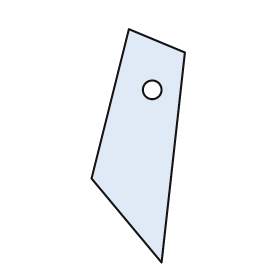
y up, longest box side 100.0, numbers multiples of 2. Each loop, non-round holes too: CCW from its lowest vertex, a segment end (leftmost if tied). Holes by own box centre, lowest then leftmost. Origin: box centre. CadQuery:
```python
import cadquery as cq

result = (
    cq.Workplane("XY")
    .moveTo(10.0, -50.0)
    .lineTo(20.0, 40.0)
    .lineTo(-4.0, 50.0)
    .lineTo(-20.0, -14.0)
    .close()
    .moveTo(6.0, 24.0)
    .circle(4.0)
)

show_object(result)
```